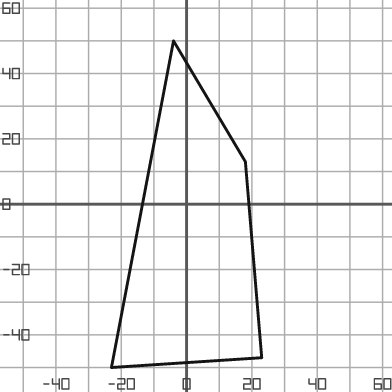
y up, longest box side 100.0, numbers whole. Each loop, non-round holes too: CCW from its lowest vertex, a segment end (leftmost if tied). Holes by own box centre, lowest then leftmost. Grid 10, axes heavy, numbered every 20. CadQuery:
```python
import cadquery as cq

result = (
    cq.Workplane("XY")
    .moveTo(-23.0, -50.0)
    .lineTo(23.0, -47.0)
    .lineTo(18.0, 13.0)
    .lineTo(-4.0, 50.0)
    .close()
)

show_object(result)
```